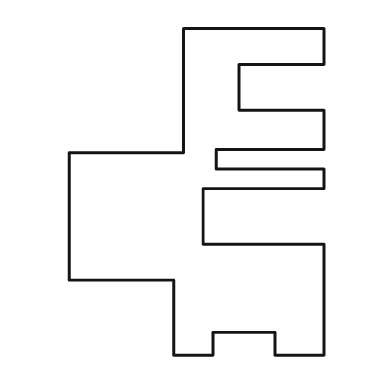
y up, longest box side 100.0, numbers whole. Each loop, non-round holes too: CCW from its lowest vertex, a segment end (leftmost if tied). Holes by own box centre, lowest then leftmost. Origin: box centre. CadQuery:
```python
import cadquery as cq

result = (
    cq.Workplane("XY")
    .moveTo(-7.0, -50.0)
    .lineTo(5.0, -50.0)
    .lineTo(5.0, -43.0)
    .lineTo(24.0, -43.0)
    .lineTo(24.0, -50.0)
    .lineTo(39.0, -50.0)
    .lineTo(39.0, -16.0)
    .lineTo(2.0, -16.0)
    .lineTo(2.0, 1.0)
    .lineTo(39.0, 1.0)
    .lineTo(39.0, 7.0)
    .lineTo(6.0, 7.0)
    .lineTo(6.0, 13.0)
    .lineTo(39.0, 13.0)
    .lineTo(39.0, 25.0)
    .lineTo(13.0, 25.0)
    .lineTo(13.0, 39.0)
    .lineTo(39.0, 39.0)
    .lineTo(39.0, 50.0)
    .lineTo(-4.0, 50.0)
    .lineTo(-4.0, 12.0)
    .lineTo(-39.0, 12.0)
    .lineTo(-39.0, -27.0)
    .lineTo(-7.0, -27.0)
    .close()
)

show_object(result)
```